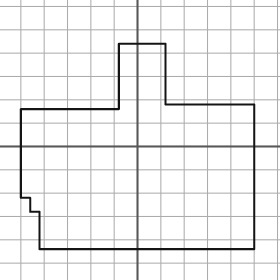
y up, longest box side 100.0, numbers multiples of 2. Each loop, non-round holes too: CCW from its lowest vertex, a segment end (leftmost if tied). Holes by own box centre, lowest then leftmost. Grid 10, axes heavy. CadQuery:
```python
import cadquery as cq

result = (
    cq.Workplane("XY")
    .moveTo(-42.0, -44.0)
    .lineTo(50.0, -44.0)
    .lineTo(50.0, 18.0)
    .lineTo(12.0, 18.0)
    .lineTo(12.0, 44.0)
    .lineTo(-8.0, 44.0)
    .lineTo(-8.0, 16.0)
    .lineTo(-50.0, 16.0)
    .lineTo(-50.0, -22.0)
    .lineTo(-46.0, -22.0)
    .lineTo(-46.0, -28.0)
    .lineTo(-42.0, -28.0)
    .close()
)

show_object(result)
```